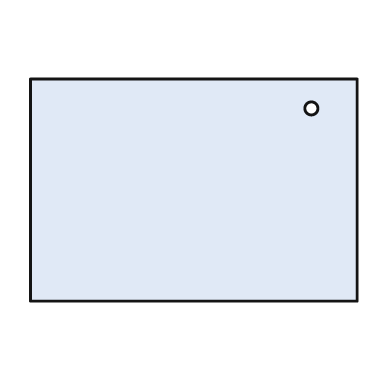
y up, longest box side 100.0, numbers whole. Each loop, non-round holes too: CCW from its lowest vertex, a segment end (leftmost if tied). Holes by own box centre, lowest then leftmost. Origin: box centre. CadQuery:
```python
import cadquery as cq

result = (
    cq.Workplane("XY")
    .moveTo(-50.0, -34.0)
    .lineTo(50.0, -34.0)
    .lineTo(50.0, 34.0)
    .lineTo(-50.0, 34.0)
    .close()
    .moveTo(36.0, 25.0)
    .circle(2.0)
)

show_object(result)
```